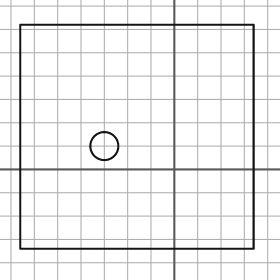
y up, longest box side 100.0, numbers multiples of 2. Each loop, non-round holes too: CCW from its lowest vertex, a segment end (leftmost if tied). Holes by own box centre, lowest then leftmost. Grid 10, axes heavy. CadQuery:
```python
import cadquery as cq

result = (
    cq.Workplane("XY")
    .moveTo(-66.0, -34.0)
    .lineTo(34.0, -34.0)
    .lineTo(34.0, 62.0)
    .lineTo(-66.0, 62.0)
    .close()
    .moveTo(-30.0, 10.0)
    .circle(6.0)
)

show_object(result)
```